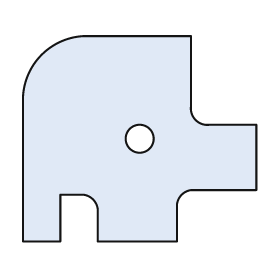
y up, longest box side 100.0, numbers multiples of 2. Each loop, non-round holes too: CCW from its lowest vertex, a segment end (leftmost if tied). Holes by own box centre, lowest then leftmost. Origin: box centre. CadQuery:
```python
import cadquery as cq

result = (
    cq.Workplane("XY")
    .moveTo(-50.0, -44.0)
    .lineTo(-34.0, -44.0)
    .lineTo(-34.0, -24.0)
    .lineTo(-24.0, -24.0)
    .threePointArc((-20.0, -26.0), (-18.0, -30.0))
    .lineTo(-18.0, -44.0)
    .lineTo(16.0, -44.0)
    .lineTo(16.0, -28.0)
    .threePointArc((18.0, -24.0), (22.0, -22.0))
    .lineTo(50.0, -22.0)
    .lineTo(50.0, 6.0)
    .lineTo(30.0, 6.0)
    .threePointArc((24.0, 8.0), (22.0, 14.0))
    .lineTo(22.0, 44.0)
    .lineTo(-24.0, 44.0)
    .threePointArc((-42.0, 36.0), (-50.0, 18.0))
    .close()
    .moveTo(0.0, 0.0)
    .circle(6.0)
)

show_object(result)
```